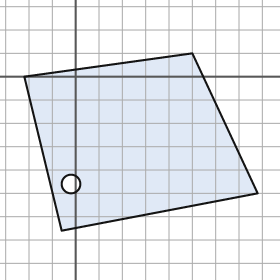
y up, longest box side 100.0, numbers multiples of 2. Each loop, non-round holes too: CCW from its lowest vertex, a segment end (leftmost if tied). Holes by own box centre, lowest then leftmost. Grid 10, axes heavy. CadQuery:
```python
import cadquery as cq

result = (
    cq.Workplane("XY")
    .moveTo(-6.0, -66.0)
    .lineTo(78.0, -50.0)
    .lineTo(50.0, 10.0)
    .lineTo(-22.0, 0.0)
    .close()
    .moveTo(-2.0, -46.0)
    .circle(4.0)
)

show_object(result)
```